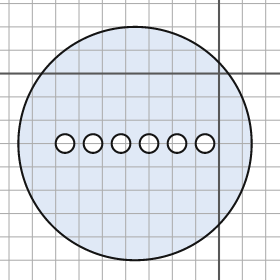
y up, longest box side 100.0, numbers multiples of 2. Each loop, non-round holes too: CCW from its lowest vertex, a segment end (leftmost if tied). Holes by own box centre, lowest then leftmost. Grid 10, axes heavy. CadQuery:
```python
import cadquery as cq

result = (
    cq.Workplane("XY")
    .moveTo(-36.0, -30.0)
    .circle(50.0)
    .moveTo(-66.0, -30.0)
    .circle(4.0)
    .moveTo(-54.0, -30.0)
    .circle(4.0)
    .moveTo(-42.0, -30.0)
    .circle(4.0)
    .moveTo(-30.0, -30.0)
    .circle(4.0)
    .moveTo(-18.0, -30.0)
    .circle(4.0)
    .moveTo(-6.0, -30.0)
    .circle(4.0)
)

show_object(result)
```